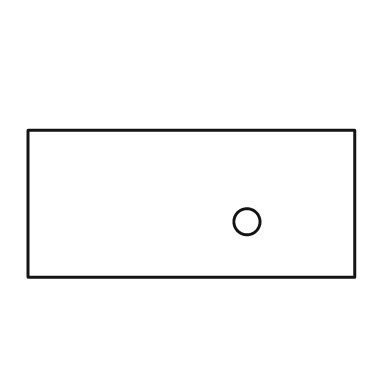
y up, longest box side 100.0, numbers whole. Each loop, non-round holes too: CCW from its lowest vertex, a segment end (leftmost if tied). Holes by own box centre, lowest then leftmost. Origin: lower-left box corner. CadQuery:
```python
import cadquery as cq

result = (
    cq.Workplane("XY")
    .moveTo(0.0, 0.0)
    .lineTo(100.0, 0.0)
    .lineTo(100.0, 45.0)
    .lineTo(0.0, 45.0)
    .close()
    .moveTo(67.0, 17.0)
    .circle(4.0)
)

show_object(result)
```